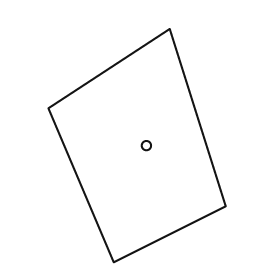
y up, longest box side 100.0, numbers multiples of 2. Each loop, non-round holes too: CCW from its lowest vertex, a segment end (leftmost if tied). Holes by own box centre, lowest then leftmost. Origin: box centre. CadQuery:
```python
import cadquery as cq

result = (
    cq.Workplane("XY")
    .moveTo(-10.0, -50.0)
    .lineTo(38.0, -26.0)
    .lineTo(14.0, 50.0)
    .lineTo(-38.0, 16.0)
    .close()
    .moveTo(4.0, 0.0)
    .circle(2.0)
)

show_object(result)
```